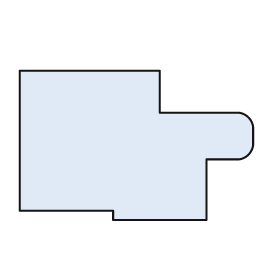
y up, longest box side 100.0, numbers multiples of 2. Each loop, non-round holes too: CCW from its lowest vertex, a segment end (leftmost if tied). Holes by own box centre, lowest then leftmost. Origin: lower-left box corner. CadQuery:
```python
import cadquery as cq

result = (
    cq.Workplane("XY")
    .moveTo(40.0, 0.0)
    .lineTo(80.0, 0.0)
    .lineTo(80.0, 26.0)
    .lineTo(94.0, 26.0)
    .threePointArc((98.0, 28.0), (100.0, 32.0))
    .lineTo(100.0, 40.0)
    .threePointArc((98.0, 44.0), (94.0, 46.0))
    .lineTo(60.0, 46.0)
    .lineTo(60.0, 64.0)
    .lineTo(0.0, 64.0)
    .lineTo(0.0, 4.0)
    .lineTo(40.0, 4.0)
    .close()
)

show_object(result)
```